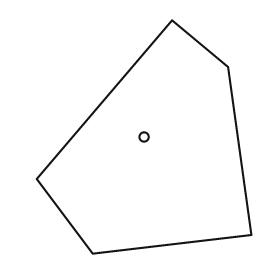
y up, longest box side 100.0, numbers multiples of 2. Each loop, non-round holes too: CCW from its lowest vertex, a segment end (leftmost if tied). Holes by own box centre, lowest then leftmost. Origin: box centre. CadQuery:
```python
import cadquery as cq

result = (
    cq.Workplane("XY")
    .moveTo(-22.0, -50.0)
    .lineTo(46.0, -42.0)
    .lineTo(36.0, 30.0)
    .lineTo(12.0, 50.0)
    .lineTo(-46.0, -18.0)
    .close()
    .moveTo(0.0, 0.0)
    .circle(2.0)
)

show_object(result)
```